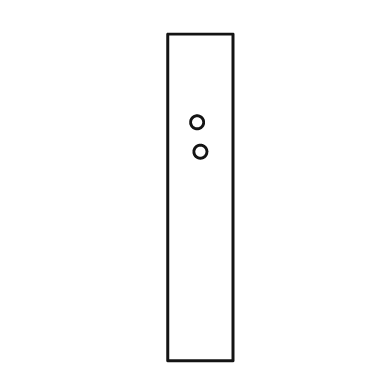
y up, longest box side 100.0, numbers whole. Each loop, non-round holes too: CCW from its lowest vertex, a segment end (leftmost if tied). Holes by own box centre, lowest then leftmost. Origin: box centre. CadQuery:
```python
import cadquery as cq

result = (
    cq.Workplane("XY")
    .moveTo(-10.0, -50.0)
    .lineTo(10.0, -50.0)
    .lineTo(10.0, 50.0)
    .lineTo(-10.0, 50.0)
    .close()
    .moveTo(0.0, 14.0)
    .circle(2.0)
    .moveTo(-1.0, 23.0)
    .circle(2.0)
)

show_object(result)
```